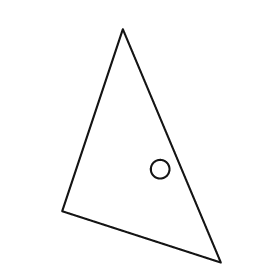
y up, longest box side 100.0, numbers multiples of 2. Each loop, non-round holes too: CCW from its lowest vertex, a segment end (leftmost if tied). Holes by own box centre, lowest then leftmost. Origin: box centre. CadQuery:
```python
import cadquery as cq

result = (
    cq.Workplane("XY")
    .moveTo(34.0, -50.0)
    .lineTo(-8.0, 50.0)
    .lineTo(-34.0, -28.0)
    .close()
    .moveTo(8.0, -10.0)
    .circle(4.0)
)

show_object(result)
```